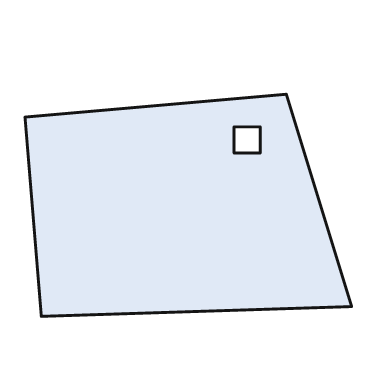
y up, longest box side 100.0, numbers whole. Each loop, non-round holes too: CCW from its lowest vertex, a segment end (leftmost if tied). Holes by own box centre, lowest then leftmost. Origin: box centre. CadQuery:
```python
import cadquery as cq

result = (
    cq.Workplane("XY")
    .moveTo(-45.0, -34.0)
    .lineTo(50.0, -31.0)
    .lineTo(30.0, 34.0)
    .lineTo(-50.0, 27.0)
    .close()
    .moveTo(14.0, 16.0)
    .lineTo(22.0, 16.0)
    .lineTo(22.0, 24.0)
    .lineTo(14.0, 24.0)
    .close()
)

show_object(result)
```